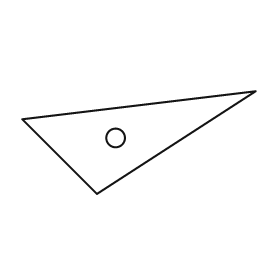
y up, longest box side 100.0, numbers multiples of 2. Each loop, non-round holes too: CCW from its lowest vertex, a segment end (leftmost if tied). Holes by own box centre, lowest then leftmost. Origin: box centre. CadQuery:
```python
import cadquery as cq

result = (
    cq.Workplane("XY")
    .moveTo(-18.0, -22.0)
    .lineTo(50.0, 22.0)
    .lineTo(-50.0, 10.0)
    .close()
    .moveTo(-10.0, 2.0)
    .circle(4.0)
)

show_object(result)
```